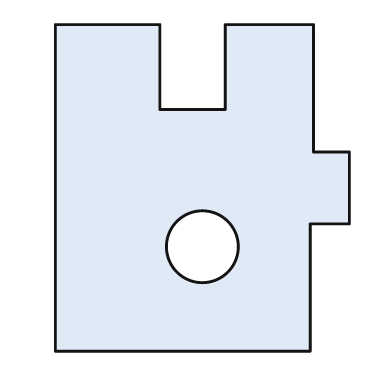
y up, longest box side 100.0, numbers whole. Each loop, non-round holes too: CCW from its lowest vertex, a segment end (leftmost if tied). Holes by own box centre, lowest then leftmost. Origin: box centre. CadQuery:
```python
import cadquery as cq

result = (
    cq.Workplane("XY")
    .moveTo(-45.0, -50.0)
    .lineTo(33.0, -50.0)
    .lineTo(33.0, -11.0)
    .lineTo(45.0, -11.0)
    .lineTo(45.0, 11.0)
    .lineTo(34.0, 11.0)
    .lineTo(34.0, 50.0)
    .lineTo(7.0, 50.0)
    .lineTo(7.0, 24.0)
    .lineTo(-13.0, 24.0)
    .lineTo(-13.0, 50.0)
    .lineTo(-45.0, 50.0)
    .close()
    .moveTo(0.0, -18.0)
    .circle(11.0)
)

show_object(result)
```